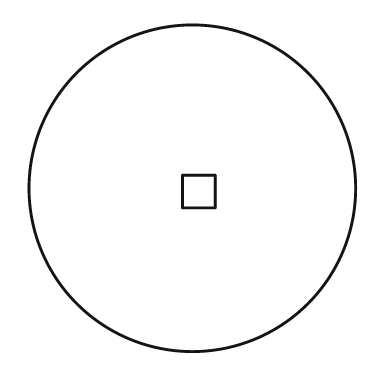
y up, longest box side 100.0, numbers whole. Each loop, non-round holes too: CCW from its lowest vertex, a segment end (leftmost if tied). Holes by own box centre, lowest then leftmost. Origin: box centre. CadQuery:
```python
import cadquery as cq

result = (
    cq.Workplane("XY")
    .moveTo(0.0, 0.0)
    .circle(50.0)
    .moveTo(-3.0, -6.0)
    .lineTo(7.0, -6.0)
    .lineTo(7.0, 4.0)
    .lineTo(-3.0, 4.0)
    .close()
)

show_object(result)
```